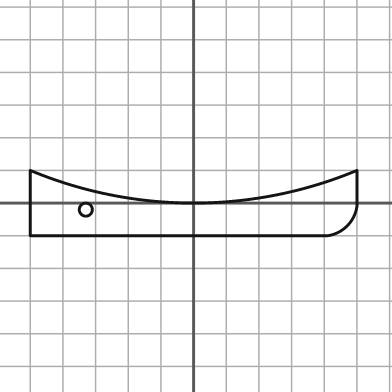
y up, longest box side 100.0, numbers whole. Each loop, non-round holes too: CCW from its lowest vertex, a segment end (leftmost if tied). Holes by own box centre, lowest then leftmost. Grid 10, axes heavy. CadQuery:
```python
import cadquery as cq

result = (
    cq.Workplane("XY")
    .moveTo(-50.0, -10.0)
    .lineTo(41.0, -10.0)
    .threePointArc((47.0, -7.0), (50.0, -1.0))
    .lineTo(50.0, 10.0)
    .threePointArc((0.0, 0.0), (-50.0, 10.0))
    .close()
    .moveTo(-33.0, -2.0)
    .circle(2.0)
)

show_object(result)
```